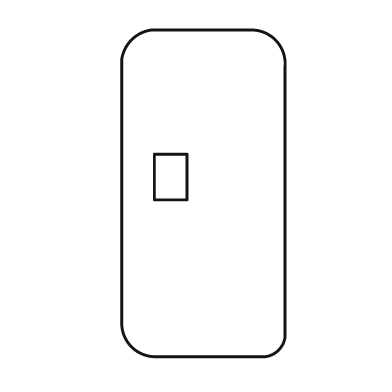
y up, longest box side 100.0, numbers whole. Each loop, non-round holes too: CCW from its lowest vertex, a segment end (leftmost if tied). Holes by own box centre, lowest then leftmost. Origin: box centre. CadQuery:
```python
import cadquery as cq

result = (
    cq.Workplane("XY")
    .moveTo(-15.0, -50.0)
    .lineTo(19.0, -50.0)
    .threePointArc((23.0, -48.0), (25.0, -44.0))
    .lineTo(25.0, 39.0)
    .threePointArc((22.0, 47.0), (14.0, 50.0))
    .lineTo(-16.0, 50.0)
    .threePointArc((-22.0, 47.0), (-25.0, 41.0))
    .lineTo(-25.0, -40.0)
    .threePointArc((-22.0, -47.0), (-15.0, -50.0))
    .close()
    .moveTo(-15.0, -2.0)
    .lineTo(-5.0, -2.0)
    .lineTo(-5.0, 12.0)
    .lineTo(-15.0, 12.0)
    .close()
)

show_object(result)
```